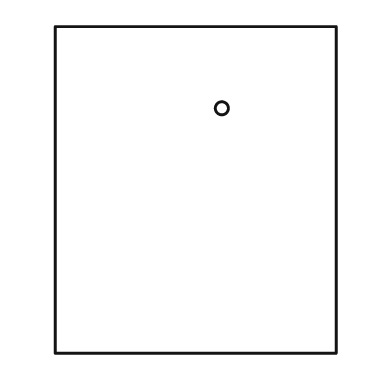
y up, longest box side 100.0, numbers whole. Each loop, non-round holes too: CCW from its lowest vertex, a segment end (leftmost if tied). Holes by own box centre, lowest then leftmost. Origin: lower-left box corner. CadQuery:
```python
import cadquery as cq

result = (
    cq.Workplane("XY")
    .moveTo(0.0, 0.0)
    .lineTo(86.0, 0.0)
    .lineTo(86.0, 100.0)
    .lineTo(0.0, 100.0)
    .close()
    .moveTo(51.0, 75.0)
    .circle(2.0)
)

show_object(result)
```